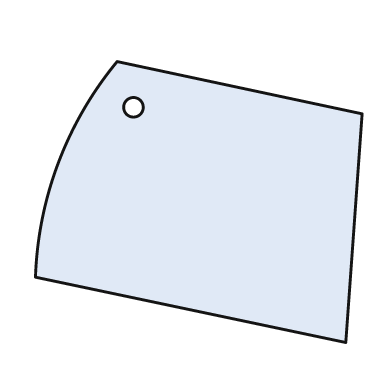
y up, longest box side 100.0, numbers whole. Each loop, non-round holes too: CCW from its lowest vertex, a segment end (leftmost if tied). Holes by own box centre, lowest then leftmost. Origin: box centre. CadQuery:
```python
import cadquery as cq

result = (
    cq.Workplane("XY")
    .moveTo(45.0, -43.0)
    .lineTo(50.0, 27.0)
    .lineTo(-25.0, 43.0)
    .threePointArc((-43.0, 12.0), (-50.0, -23.0))
    .close()
    .moveTo(-20.0, 29.0)
    .circle(3.0)
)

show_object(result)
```